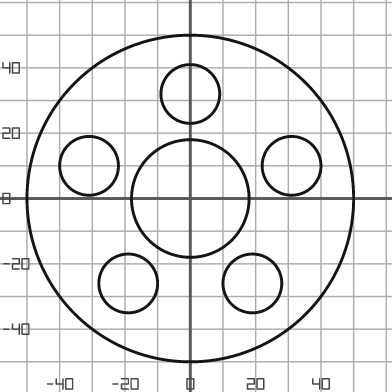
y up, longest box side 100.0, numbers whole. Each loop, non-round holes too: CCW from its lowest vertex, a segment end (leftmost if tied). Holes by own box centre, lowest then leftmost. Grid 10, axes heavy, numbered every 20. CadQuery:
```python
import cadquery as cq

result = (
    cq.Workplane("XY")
    .moveTo(0.0, 0.0)
    .circle(50.0)
    .moveTo(-19.0, -26.0)
    .circle(9.0)
    .moveTo(19.0, -26.0)
    .circle(9.0)
    .moveTo(0.0, 0.0)
    .circle(18.0)
    .moveTo(-31.0, 10.0)
    .circle(9.0)
    .moveTo(31.0, 10.0)
    .circle(9.0)
    .moveTo(0.0, 32.0)
    .circle(9.0)
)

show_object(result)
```